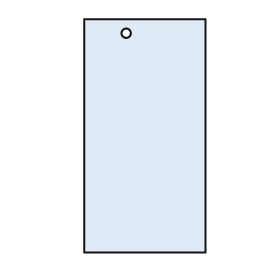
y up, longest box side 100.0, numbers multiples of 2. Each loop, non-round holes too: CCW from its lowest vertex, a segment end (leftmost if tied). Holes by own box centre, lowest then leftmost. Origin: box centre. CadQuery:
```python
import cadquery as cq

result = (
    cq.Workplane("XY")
    .moveTo(-26.0, -50.0)
    .lineTo(26.0, -50.0)
    .lineTo(26.0, 50.0)
    .lineTo(-26.0, 50.0)
    .close()
    .moveTo(-8.0, 44.0)
    .circle(2.0)
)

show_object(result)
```